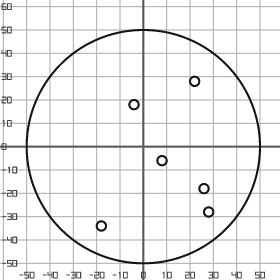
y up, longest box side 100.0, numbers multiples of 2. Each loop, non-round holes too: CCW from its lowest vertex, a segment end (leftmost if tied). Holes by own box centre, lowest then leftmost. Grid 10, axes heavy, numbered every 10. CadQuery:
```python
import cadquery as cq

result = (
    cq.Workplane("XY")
    .moveTo(0.0, 0.0)
    .circle(50.0)
    .moveTo(-18.0, -34.0)
    .circle(2.0)
    .moveTo(28.0, -28.0)
    .circle(2.0)
    .moveTo(26.0, -18.0)
    .circle(2.0)
    .moveTo(8.0, -6.0)
    .circle(2.0)
    .moveTo(-4.0, 18.0)
    .circle(2.0)
    .moveTo(22.0, 28.0)
    .circle(2.0)
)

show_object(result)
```